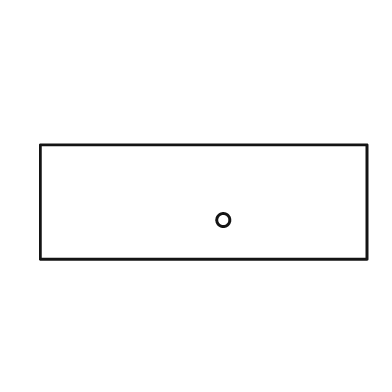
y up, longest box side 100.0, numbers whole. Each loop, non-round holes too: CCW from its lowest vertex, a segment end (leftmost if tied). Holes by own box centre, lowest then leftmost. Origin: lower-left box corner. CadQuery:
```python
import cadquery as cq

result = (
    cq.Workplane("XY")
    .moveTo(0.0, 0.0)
    .lineTo(100.0, 0.0)
    .lineTo(100.0, 35.0)
    .lineTo(0.0, 35.0)
    .close()
    .moveTo(56.0, 12.0)
    .circle(2.0)
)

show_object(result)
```